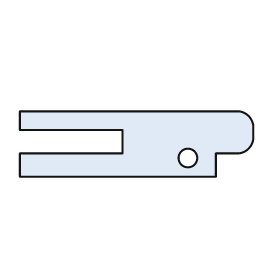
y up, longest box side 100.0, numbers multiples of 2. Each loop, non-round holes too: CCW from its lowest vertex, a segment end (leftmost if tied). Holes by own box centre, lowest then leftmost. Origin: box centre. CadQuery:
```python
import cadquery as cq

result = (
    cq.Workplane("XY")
    .moveTo(-50.0, -14.0)
    .lineTo(34.0, -14.0)
    .lineTo(34.0, -4.0)
    .lineTo(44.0, -4.0)
    .threePointArc((48.0, -2.0), (50.0, 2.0))
    .lineTo(50.0, 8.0)
    .threePointArc((48.0, 12.0), (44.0, 14.0))
    .lineTo(-50.0, 14.0)
    .lineTo(-50.0, 6.0)
    .lineTo(-6.0, 6.0)
    .lineTo(-6.0, -4.0)
    .lineTo(-50.0, -4.0)
    .close()
    .moveTo(22.0, -6.0)
    .circle(4.0)
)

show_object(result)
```